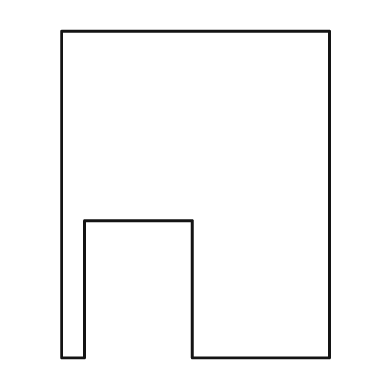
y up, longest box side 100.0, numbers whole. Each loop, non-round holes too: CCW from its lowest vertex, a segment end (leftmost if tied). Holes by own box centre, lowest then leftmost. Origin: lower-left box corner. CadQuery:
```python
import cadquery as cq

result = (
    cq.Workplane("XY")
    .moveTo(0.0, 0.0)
    .lineTo(7.0, 0.0)
    .lineTo(7.0, 42.0)
    .lineTo(40.0, 42.0)
    .lineTo(40.0, 0.0)
    .lineTo(82.0, 0.0)
    .lineTo(82.0, 100.0)
    .lineTo(0.0, 100.0)
    .close()
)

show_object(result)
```